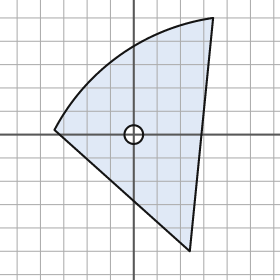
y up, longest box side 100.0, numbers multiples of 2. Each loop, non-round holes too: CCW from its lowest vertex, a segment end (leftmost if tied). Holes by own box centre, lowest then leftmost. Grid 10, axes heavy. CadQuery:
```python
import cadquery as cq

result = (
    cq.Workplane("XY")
    .moveTo(24.0, -50.0)
    .lineTo(34.0, 50.0)
    .threePointArc((-6.0, 34.0), (-34.0, 2.0))
    .close()
    .moveTo(0.0, 0.0)
    .circle(4.0)
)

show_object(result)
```